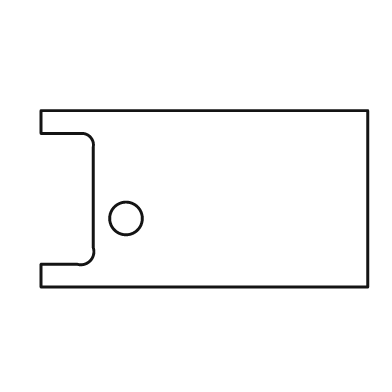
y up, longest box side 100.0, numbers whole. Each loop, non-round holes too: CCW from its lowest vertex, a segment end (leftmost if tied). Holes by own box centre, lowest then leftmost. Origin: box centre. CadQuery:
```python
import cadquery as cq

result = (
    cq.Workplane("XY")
    .moveTo(-50.0, -27.0)
    .lineTo(50.0, -27.0)
    .lineTo(50.0, 27.0)
    .lineTo(-50.0, 27.0)
    .lineTo(-50.0, 20.0)
    .lineTo(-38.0, 20.0)
    .threePointArc((-35.0, 19.0), (-34.0, 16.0))
    .lineTo(-34.0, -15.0)
    .threePointArc((-35.0, -19.0), (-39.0, -20.0))
    .lineTo(-50.0, -20.0)
    .close()
    .moveTo(-24.0, -6.0)
    .circle(5.0)
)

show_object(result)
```